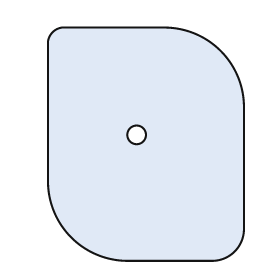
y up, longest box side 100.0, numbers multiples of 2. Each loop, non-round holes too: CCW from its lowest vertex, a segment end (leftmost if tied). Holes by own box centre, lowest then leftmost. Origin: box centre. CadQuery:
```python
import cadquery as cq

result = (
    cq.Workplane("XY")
    .moveTo(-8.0, -50.0)
    .lineTo(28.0, -50.0)
    .threePointArc((38.0, -46.0), (42.0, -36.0))
    .lineTo(42.0, 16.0)
    .threePointArc((32.0, 40.0), (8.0, 50.0))
    .lineTo(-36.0, 50.0)
    .threePointArc((-40.0, 48.0), (-42.0, 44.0))
    .lineTo(-42.0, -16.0)
    .threePointArc((-32.0, -40.0), (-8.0, -50.0))
    .close()
    .moveTo(-4.0, 4.0)
    .circle(4.0)
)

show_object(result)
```